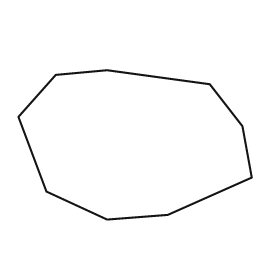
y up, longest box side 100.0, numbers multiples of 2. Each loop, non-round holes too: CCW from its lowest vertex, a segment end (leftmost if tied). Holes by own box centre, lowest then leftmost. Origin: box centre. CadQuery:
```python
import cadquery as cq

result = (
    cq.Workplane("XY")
    .moveTo(-12.0, -32.0)
    .lineTo(14.0, -30.0)
    .lineTo(50.0, -14.0)
    .lineTo(46.0, 8.0)
    .lineTo(32.0, 26.0)
    .lineTo(-12.0, 32.0)
    .lineTo(-34.0, 30.0)
    .lineTo(-50.0, 12.0)
    .lineTo(-38.0, -20.0)
    .close()
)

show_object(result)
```